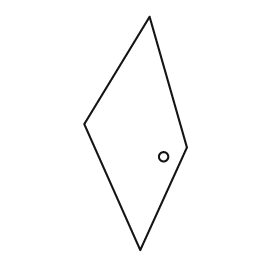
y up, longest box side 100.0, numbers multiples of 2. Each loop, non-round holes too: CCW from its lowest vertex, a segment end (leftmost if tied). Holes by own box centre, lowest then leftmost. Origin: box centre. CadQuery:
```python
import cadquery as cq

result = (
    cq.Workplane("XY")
    .moveTo(2.0, -50.0)
    .lineTo(22.0, -6.0)
    .lineTo(6.0, 50.0)
    .lineTo(-22.0, 4.0)
    .close()
    .moveTo(12.0, -10.0)
    .circle(2.0)
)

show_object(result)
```